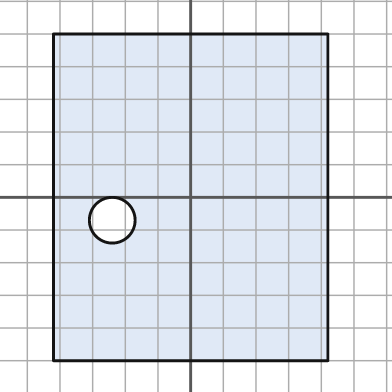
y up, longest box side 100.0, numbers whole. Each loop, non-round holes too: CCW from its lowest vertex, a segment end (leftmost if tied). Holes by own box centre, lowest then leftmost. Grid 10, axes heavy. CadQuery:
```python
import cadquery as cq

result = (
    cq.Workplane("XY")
    .moveTo(-42.0, -50.0)
    .lineTo(42.0, -50.0)
    .lineTo(42.0, 50.0)
    .lineTo(-42.0, 50.0)
    .close()
    .moveTo(-24.0, -7.0)
    .circle(7.0)
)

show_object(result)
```